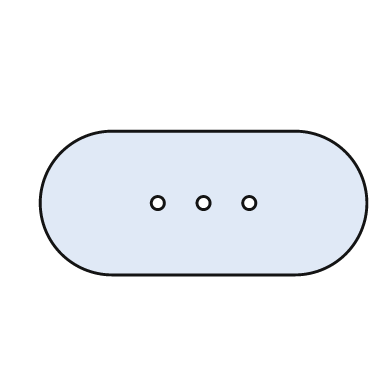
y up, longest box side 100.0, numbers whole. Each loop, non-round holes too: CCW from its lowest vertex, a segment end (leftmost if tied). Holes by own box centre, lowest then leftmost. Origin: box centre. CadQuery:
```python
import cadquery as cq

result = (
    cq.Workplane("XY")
    .moveTo(-28.0, -22.0)
    .lineTo(28.0, -22.0)
    .threePointArc((50.0, 0.0), (28.0, 22.0))
    .lineTo(-28.0, 22.0)
    .threePointArc((-50.0, 0.0), (-28.0, -22.0))
    .close()
    .moveTo(-14.0, 0.0)
    .circle(2.0)
    .moveTo(0.0, 0.0)
    .circle(2.0)
    .moveTo(14.0, 0.0)
    .circle(2.0)
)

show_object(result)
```